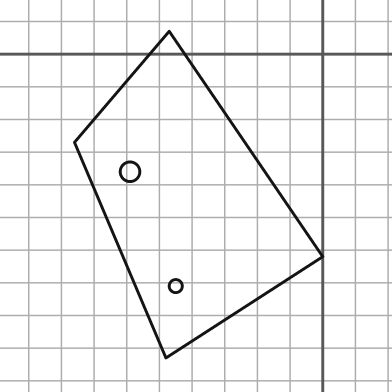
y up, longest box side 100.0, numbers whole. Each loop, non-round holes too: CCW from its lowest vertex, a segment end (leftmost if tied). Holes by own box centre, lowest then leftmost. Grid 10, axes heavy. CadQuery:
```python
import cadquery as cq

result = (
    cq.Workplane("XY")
    .moveTo(-48.0, -93.0)
    .lineTo(0.0, -62.0)
    .lineTo(-47.0, 7.0)
    .lineTo(-76.0, -27.0)
    .close()
    .moveTo(-45.0, -71.0)
    .circle(2.0)
    .moveTo(-59.0, -36.0)
    .circle(3.0)
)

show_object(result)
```